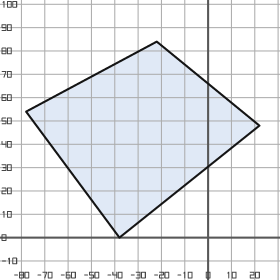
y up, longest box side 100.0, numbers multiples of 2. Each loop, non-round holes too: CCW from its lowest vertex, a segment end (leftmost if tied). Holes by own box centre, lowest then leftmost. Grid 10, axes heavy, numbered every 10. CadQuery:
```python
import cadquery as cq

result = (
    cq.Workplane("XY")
    .moveTo(-38.0, 0.0)
    .lineTo(22.0, 48.0)
    .lineTo(-22.0, 84.0)
    .lineTo(-78.0, 54.0)
    .close()
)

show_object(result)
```